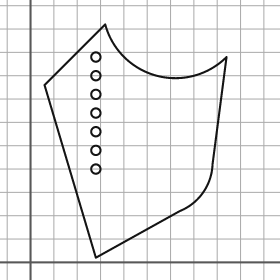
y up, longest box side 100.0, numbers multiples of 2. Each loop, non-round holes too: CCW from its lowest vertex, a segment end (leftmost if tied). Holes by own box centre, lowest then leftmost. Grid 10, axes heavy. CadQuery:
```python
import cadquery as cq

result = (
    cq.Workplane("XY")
    .moveTo(28.0, 2.0)
    .lineTo(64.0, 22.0)
    .threePointArc((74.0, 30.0), (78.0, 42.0))
    .lineTo(84.0, 88.0)
    .threePointArc((54.0, 80.0), (32.0, 102.0))
    .lineTo(6.0, 76.0)
    .close()
    .moveTo(28.0, 40.0)
    .circle(2.0)
    .moveTo(28.0, 48.0)
    .circle(2.0)
    .moveTo(28.0, 56.0)
    .circle(2.0)
    .moveTo(28.0, 64.0)
    .circle(2.0)
    .moveTo(28.0, 72.0)
    .circle(2.0)
    .moveTo(28.0, 80.0)
    .circle(2.0)
    .moveTo(28.0, 88.0)
    .circle(2.0)
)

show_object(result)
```